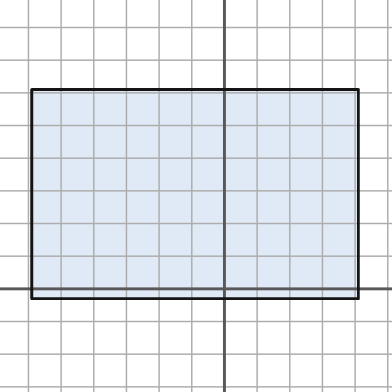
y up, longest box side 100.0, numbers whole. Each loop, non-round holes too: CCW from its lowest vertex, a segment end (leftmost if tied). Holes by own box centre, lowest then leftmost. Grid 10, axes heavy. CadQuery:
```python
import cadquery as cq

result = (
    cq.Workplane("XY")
    .moveTo(-59.0, -3.0)
    .lineTo(41.0, -3.0)
    .lineTo(41.0, 61.0)
    .lineTo(-59.0, 61.0)
    .close()
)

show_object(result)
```